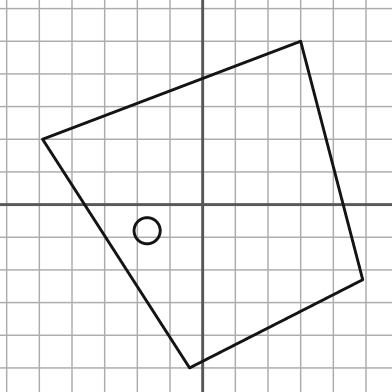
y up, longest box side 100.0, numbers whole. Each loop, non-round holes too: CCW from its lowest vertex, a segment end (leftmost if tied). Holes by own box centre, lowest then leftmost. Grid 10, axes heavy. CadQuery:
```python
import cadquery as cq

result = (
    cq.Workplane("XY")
    .moveTo(-4.0, -50.0)
    .lineTo(49.0, -23.0)
    .lineTo(30.0, 50.0)
    .lineTo(-49.0, 20.0)
    .close()
    .moveTo(-17.0, -8.0)
    .circle(4.0)
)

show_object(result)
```